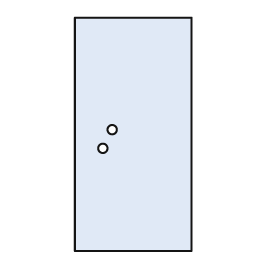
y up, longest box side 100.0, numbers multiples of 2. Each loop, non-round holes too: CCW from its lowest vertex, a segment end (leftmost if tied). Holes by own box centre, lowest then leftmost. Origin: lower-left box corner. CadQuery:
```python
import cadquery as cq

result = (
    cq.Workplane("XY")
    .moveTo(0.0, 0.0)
    .lineTo(50.0, 0.0)
    .lineTo(50.0, 100.0)
    .lineTo(0.0, 100.0)
    .close()
    .moveTo(12.0, 44.0)
    .circle(2.0)
    .moveTo(16.0, 52.0)
    .circle(2.0)
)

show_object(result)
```